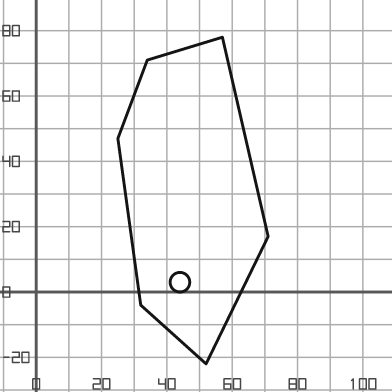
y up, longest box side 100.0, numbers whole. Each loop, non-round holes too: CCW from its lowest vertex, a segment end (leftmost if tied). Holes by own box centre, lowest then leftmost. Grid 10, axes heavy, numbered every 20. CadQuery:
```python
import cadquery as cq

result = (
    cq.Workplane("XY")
    .moveTo(52.0, -22.0)
    .lineTo(71.0, 17.0)
    .lineTo(57.0, 78.0)
    .lineTo(34.0, 71.0)
    .lineTo(25.0, 47.0)
    .lineTo(32.0, -4.0)
    .close()
    .moveTo(44.0, 3.0)
    .circle(3.0)
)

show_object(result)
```